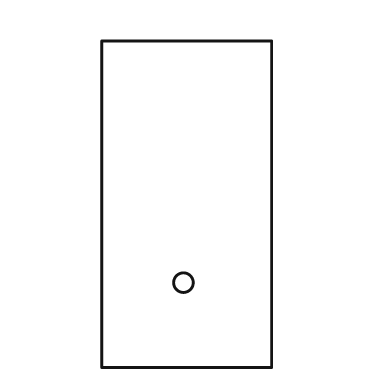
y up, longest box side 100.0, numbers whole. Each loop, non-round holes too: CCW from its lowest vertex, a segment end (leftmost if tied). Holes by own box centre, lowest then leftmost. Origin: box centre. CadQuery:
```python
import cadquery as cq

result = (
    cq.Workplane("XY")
    .moveTo(-26.0, -50.0)
    .lineTo(26.0, -50.0)
    .lineTo(26.0, 50.0)
    .lineTo(-26.0, 50.0)
    .close()
    .moveTo(-1.0, -24.0)
    .circle(3.0)
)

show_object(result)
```